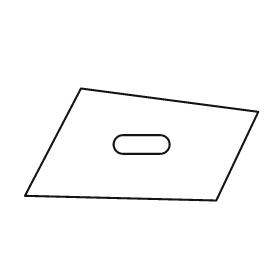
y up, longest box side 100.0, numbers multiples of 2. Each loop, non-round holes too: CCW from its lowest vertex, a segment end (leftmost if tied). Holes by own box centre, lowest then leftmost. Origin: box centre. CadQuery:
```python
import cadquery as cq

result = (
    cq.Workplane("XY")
    .moveTo(32.0, -24.0)
    .lineTo(50.0, 14.0)
    .lineTo(-26.0, 24.0)
    .lineTo(-50.0, -22.0)
    .close()
    .moveTo(-8.0, -4.0)
    .lineTo(8.0, -4.0)
    .threePointArc((12.0, 0.0), (8.0, 4.0))
    .lineTo(-8.0, 4.0)
    .threePointArc((-12.0, 0.0), (-8.0, -4.0))
    .close()
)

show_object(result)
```